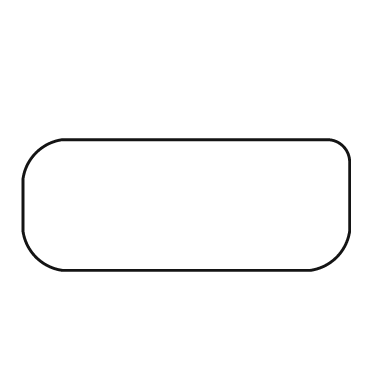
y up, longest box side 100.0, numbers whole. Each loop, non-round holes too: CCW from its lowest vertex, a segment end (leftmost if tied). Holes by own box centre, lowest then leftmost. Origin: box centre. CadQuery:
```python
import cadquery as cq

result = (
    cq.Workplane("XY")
    .moveTo(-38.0, -20.0)
    .lineTo(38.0, -20.0)
    .threePointArc((46.0, -16.0), (50.0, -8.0))
    .lineTo(50.0, 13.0)
    .threePointArc((48.0, 18.0), (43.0, 20.0))
    .lineTo(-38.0, 20.0)
    .threePointArc((-46.0, 16.0), (-50.0, 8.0))
    .lineTo(-50.0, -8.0)
    .threePointArc((-46.0, -16.0), (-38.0, -20.0))
    .close()
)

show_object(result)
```